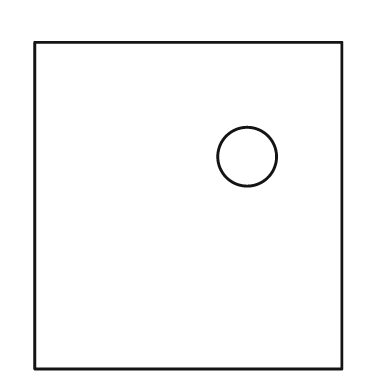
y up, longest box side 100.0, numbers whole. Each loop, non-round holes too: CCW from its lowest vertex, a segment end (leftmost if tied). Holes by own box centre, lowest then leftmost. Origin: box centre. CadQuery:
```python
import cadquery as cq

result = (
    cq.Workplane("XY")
    .moveTo(-47.0, -50.0)
    .lineTo(47.0, -50.0)
    .lineTo(47.0, 50.0)
    .lineTo(-47.0, 50.0)
    .close()
    .moveTo(18.0, 15.0)
    .circle(9.0)
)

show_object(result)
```